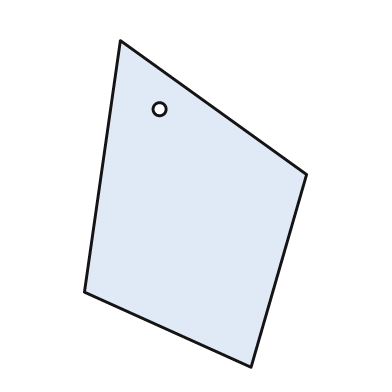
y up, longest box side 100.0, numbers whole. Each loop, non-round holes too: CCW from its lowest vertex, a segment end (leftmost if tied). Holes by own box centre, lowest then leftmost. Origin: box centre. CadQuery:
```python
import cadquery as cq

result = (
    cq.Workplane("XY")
    .moveTo(17.0, -50.0)
    .lineTo(34.0, 9.0)
    .lineTo(-23.0, 50.0)
    .lineTo(-34.0, -27.0)
    .close()
    .moveTo(-11.0, 29.0)
    .circle(2.0)
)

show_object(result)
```